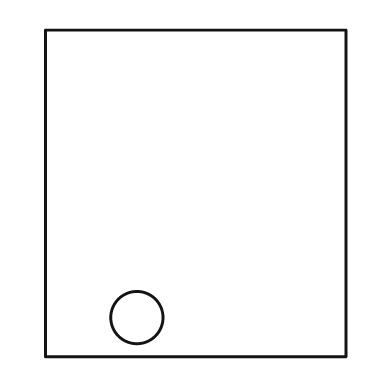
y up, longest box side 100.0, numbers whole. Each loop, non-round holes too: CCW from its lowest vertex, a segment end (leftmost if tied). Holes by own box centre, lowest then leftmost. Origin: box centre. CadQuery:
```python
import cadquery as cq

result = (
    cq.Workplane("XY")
    .moveTo(-46.0, -50.0)
    .lineTo(46.0, -50.0)
    .lineTo(46.0, 50.0)
    .lineTo(-46.0, 50.0)
    .close()
    .moveTo(-18.0, -38.0)
    .circle(8.0)
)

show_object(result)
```